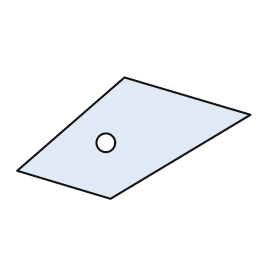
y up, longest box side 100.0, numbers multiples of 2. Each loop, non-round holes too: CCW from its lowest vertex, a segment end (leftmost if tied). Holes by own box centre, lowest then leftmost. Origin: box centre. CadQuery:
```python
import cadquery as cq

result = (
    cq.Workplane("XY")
    .moveTo(-10.0, -26.0)
    .lineTo(50.0, 10.0)
    .lineTo(-4.0, 26.0)
    .lineTo(-50.0, -14.0)
    .close()
    .moveTo(-12.0, -2.0)
    .circle(4.0)
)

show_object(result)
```